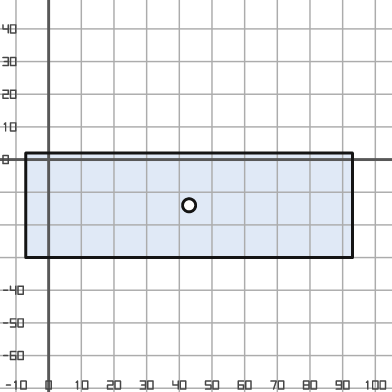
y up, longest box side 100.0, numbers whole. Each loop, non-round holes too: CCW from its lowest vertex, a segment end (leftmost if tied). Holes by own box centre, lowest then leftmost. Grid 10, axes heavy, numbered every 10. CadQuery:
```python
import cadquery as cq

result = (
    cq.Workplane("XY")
    .moveTo(-7.0, -30.0)
    .lineTo(93.0, -30.0)
    .lineTo(93.0, 2.0)
    .lineTo(-7.0, 2.0)
    .close()
    .moveTo(43.0, -14.0)
    .circle(2.0)
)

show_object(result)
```